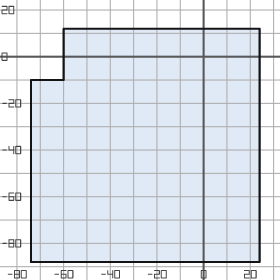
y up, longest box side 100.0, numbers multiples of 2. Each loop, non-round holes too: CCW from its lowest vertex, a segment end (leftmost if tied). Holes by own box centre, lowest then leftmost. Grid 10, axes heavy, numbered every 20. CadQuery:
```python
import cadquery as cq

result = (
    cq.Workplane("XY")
    .moveTo(-74.0, -88.0)
    .lineTo(24.0, -88.0)
    .lineTo(24.0, 12.0)
    .lineTo(-60.0, 12.0)
    .lineTo(-60.0, -10.0)
    .lineTo(-74.0, -10.0)
    .close()
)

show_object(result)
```